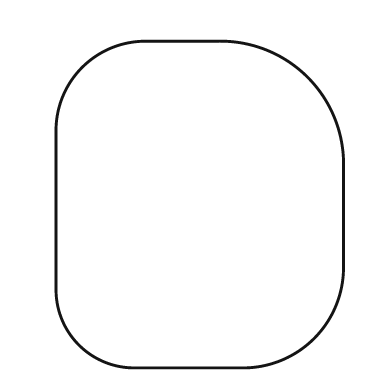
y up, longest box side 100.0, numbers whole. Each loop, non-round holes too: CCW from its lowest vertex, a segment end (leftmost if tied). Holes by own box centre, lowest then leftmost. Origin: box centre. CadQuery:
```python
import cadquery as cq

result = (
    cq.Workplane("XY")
    .moveTo(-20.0, -50.0)
    .lineTo(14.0, -50.0)
    .threePointArc((35.0, -41.0), (44.0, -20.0))
    .lineTo(44.0, 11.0)
    .threePointArc((33.0, 39.0), (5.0, 50.0))
    .lineTo(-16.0, 50.0)
    .threePointArc((-36.0, 42.0), (-44.0, 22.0))
    .lineTo(-44.0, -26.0)
    .threePointArc((-37.0, -43.0), (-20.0, -50.0))
    .close()
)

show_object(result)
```